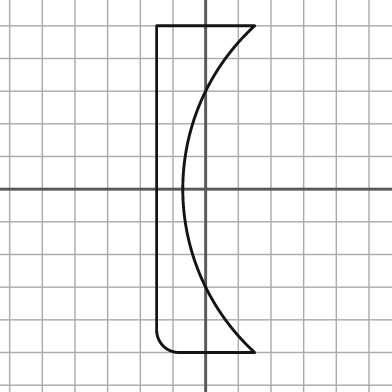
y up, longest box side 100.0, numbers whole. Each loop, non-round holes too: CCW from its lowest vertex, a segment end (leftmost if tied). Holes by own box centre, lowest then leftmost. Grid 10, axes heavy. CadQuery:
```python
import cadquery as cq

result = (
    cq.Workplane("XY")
    .moveTo(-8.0, -50.0)
    .lineTo(15.0, -50.0)
    .threePointArc((-7.0, 0.0), (15.0, 50.0))
    .lineTo(-15.0, 50.0)
    .lineTo(-15.0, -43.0)
    .threePointArc((-13.0, -48.0), (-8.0, -50.0))
    .close()
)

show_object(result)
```